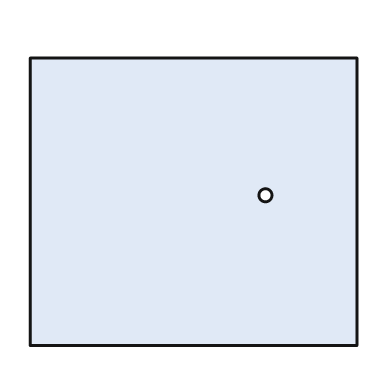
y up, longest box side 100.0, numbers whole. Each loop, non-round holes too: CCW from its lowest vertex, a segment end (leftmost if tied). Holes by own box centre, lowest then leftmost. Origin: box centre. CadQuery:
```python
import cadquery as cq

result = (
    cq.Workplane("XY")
    .moveTo(-50.0, -44.0)
    .lineTo(50.0, -44.0)
    .lineTo(50.0, 44.0)
    .lineTo(-50.0, 44.0)
    .close()
    .moveTo(22.0, 2.0)
    .circle(2.0)
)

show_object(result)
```